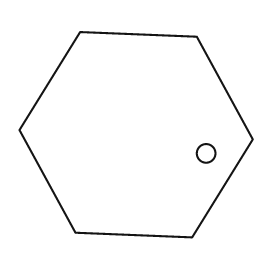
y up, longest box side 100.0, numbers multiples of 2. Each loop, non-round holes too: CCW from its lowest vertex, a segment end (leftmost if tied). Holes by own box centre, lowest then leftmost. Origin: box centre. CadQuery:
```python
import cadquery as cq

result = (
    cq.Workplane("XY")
    .moveTo(24.0, -44.0)
    .lineTo(50.0, -2.0)
    .lineTo(26.0, 42.0)
    .lineTo(-24.0, 44.0)
    .lineTo(-50.0, 2.0)
    .lineTo(-26.0, -42.0)
    .close()
    .moveTo(30.0, -8.0)
    .circle(4.0)
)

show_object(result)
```